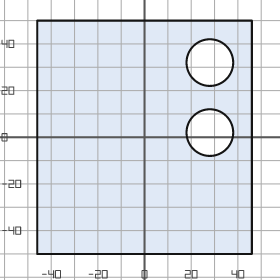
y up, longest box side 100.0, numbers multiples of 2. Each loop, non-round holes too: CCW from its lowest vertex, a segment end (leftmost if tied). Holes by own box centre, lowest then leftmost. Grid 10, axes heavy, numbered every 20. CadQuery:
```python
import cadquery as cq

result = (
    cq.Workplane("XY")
    .moveTo(-46.0, -50.0)
    .lineTo(46.0, -50.0)
    .lineTo(46.0, 50.0)
    .lineTo(-46.0, 50.0)
    .close()
    .moveTo(28.0, 2.0)
    .circle(10.0)
    .moveTo(28.0, 32.0)
    .circle(10.0)
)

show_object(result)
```